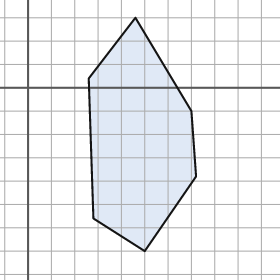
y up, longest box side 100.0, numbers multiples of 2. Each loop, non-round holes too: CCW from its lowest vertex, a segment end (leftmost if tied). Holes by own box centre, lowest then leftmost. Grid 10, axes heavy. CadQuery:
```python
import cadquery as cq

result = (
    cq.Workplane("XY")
    .moveTo(50.0, -70.0)
    .lineTo(72.0, -38.0)
    .lineTo(70.0, -10.0)
    .lineTo(46.0, 30.0)
    .lineTo(26.0, 4.0)
    .lineTo(28.0, -56.0)
    .close()
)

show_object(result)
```